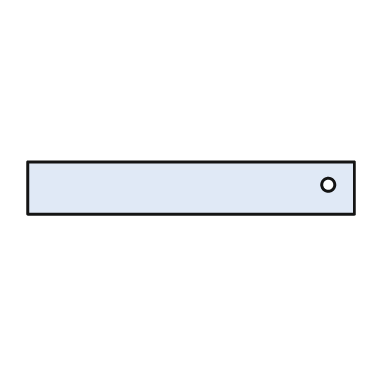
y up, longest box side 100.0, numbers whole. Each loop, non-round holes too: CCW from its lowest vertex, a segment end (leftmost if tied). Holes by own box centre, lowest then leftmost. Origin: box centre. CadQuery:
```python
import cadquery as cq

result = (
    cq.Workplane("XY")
    .moveTo(-50.0, -8.0)
    .lineTo(50.0, -8.0)
    .lineTo(50.0, 8.0)
    .lineTo(-50.0, 8.0)
    .close()
    .moveTo(42.0, 1.0)
    .circle(2.0)
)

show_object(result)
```